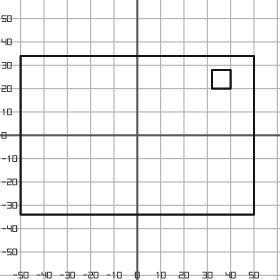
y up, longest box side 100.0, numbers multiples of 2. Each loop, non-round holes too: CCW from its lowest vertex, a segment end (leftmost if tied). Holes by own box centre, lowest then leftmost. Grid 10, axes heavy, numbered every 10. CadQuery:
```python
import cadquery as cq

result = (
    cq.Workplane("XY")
    .moveTo(-50.0, -34.0)
    .lineTo(50.0, -34.0)
    .lineTo(50.0, 34.0)
    .lineTo(-50.0, 34.0)
    .close()
    .moveTo(32.0, 20.0)
    .lineTo(40.0, 20.0)
    .lineTo(40.0, 28.0)
    .lineTo(32.0, 28.0)
    .close()
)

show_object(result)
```